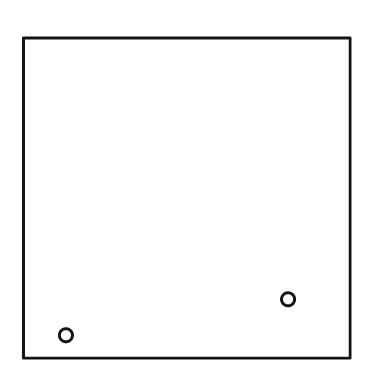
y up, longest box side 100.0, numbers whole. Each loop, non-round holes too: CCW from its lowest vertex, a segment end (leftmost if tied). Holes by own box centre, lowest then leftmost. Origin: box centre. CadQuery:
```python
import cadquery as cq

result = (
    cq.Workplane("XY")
    .moveTo(-50.0, -49.0)
    .lineTo(50.0, -49.0)
    .lineTo(50.0, 49.0)
    .lineTo(-50.0, 49.0)
    .close()
    .moveTo(-37.0, -42.0)
    .circle(2.0)
    .moveTo(31.0, -31.0)
    .circle(2.0)
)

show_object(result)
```